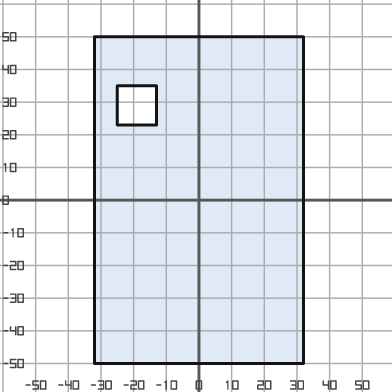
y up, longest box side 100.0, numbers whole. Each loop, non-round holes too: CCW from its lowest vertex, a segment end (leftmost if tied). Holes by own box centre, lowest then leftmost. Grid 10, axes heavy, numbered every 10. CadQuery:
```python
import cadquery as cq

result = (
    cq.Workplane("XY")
    .moveTo(-32.0, -50.0)
    .lineTo(32.0, -50.0)
    .lineTo(32.0, 50.0)
    .lineTo(-32.0, 50.0)
    .close()
    .moveTo(-25.0, 23.0)
    .lineTo(-13.0, 23.0)
    .lineTo(-13.0, 35.0)
    .lineTo(-25.0, 35.0)
    .close()
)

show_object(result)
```